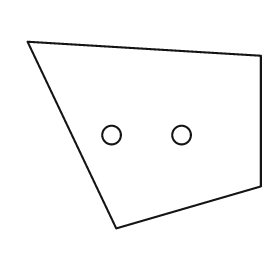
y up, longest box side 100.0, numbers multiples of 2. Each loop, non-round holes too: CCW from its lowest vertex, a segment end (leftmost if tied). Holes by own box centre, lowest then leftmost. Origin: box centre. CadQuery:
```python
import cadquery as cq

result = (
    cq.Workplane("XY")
    .moveTo(-12.0, -40.0)
    .lineTo(50.0, -22.0)
    .lineTo(50.0, 34.0)
    .lineTo(-50.0, 40.0)
    .close()
    .moveTo(-14.0, 0.0)
    .circle(4.0)
    .moveTo(16.0, 0.0)
    .circle(4.0)
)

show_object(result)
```